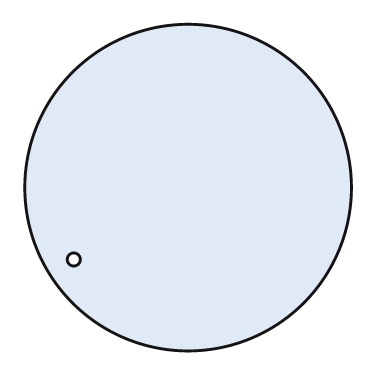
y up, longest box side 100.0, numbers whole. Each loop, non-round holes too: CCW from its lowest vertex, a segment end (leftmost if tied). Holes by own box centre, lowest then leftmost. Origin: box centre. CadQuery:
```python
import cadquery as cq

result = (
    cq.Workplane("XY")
    .moveTo(0.0, 0.0)
    .circle(50.0)
    .moveTo(-35.0, -22.0)
    .circle(2.0)
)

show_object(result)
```